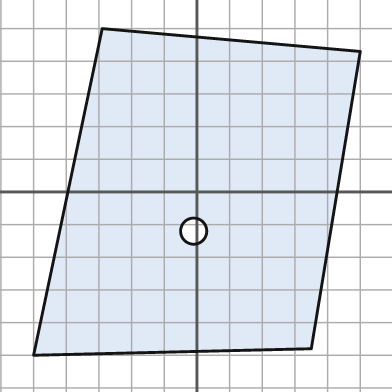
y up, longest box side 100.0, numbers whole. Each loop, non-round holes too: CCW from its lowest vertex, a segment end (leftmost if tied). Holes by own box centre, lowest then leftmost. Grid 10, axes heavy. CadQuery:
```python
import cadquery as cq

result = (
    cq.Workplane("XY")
    .moveTo(-50.0, -50.0)
    .lineTo(35.0, -48.0)
    .lineTo(50.0, 43.0)
    .lineTo(-29.0, 50.0)
    .close()
    .moveTo(-1.0, -12.0)
    .circle(4.0)
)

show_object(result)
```